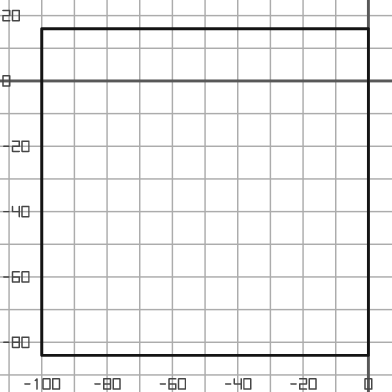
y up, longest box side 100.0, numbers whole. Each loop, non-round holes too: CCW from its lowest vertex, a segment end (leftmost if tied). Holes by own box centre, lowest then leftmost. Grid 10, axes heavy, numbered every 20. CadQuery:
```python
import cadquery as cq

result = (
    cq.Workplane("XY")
    .moveTo(-100.0, -84.0)
    .lineTo(0.0, -84.0)
    .lineTo(0.0, 16.0)
    .lineTo(-100.0, 16.0)
    .close()
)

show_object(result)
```